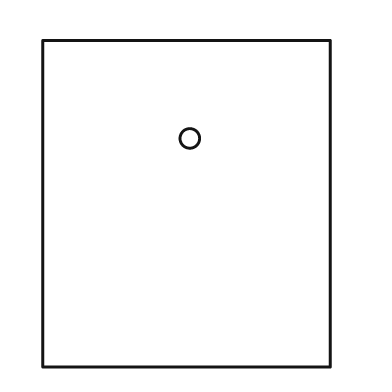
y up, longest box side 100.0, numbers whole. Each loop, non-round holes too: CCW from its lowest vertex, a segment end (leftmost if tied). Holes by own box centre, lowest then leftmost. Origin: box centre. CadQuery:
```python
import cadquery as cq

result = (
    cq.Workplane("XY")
    .moveTo(-44.0, -50.0)
    .lineTo(44.0, -50.0)
    .lineTo(44.0, 50.0)
    .lineTo(-44.0, 50.0)
    .close()
    .moveTo(1.0, 20.0)
    .circle(3.0)
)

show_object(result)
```